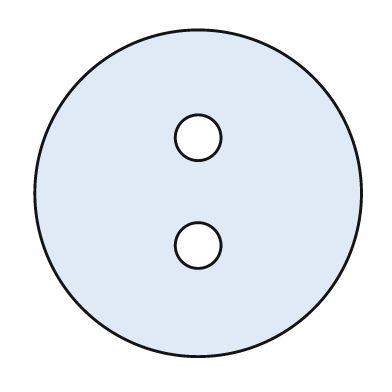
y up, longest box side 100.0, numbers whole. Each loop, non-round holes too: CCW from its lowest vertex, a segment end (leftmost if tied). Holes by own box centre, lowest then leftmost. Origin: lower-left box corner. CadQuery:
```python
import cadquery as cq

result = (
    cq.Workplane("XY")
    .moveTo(50.0, 50.0)
    .circle(50.0)
    .moveTo(50.0, 34.0)
    .circle(7.0)
    .moveTo(50.0, 67.0)
    .circle(7.0)
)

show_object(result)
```